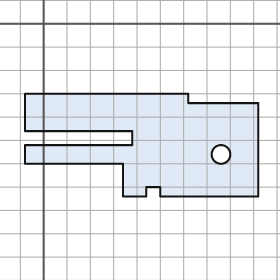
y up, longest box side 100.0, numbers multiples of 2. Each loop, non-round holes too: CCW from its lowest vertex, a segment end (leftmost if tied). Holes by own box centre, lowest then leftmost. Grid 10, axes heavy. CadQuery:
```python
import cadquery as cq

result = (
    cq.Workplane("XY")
    .moveTo(34.0, -74.0)
    .lineTo(44.0, -74.0)
    .lineTo(44.0, -70.0)
    .lineTo(50.0, -70.0)
    .lineTo(50.0, -74.0)
    .lineTo(92.0, -74.0)
    .lineTo(92.0, -34.0)
    .lineTo(62.0, -34.0)
    .lineTo(62.0, -30.0)
    .lineTo(-8.0, -30.0)
    .lineTo(-8.0, -46.0)
    .lineTo(38.0, -46.0)
    .lineTo(38.0, -52.0)
    .lineTo(-8.0, -52.0)
    .lineTo(-8.0, -60.0)
    .lineTo(34.0, -60.0)
    .close()
    .moveTo(76.0, -56.0)
    .circle(4.0)
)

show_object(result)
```